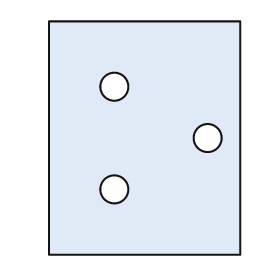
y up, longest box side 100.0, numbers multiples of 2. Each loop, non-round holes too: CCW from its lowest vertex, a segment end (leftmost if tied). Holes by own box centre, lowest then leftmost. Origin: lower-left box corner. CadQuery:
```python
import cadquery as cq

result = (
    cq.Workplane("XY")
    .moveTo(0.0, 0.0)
    .lineTo(82.0, 0.0)
    .lineTo(82.0, 100.0)
    .lineTo(0.0, 100.0)
    .close()
    .moveTo(28.0, 28.0)
    .circle(6.0)
    .moveTo(68.0, 50.0)
    .circle(6.0)
    .moveTo(28.0, 72.0)
    .circle(6.0)
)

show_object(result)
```